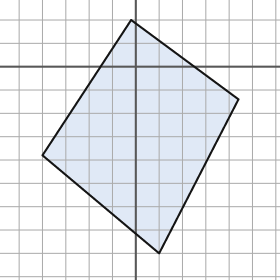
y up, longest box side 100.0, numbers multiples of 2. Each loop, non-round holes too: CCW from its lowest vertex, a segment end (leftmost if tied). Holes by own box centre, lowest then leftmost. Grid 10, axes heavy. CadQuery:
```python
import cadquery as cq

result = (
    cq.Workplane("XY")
    .moveTo(10.0, -80.0)
    .lineTo(44.0, -14.0)
    .lineTo(-2.0, 20.0)
    .lineTo(-40.0, -38.0)
    .close()
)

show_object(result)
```